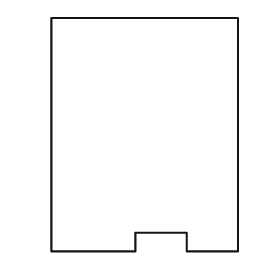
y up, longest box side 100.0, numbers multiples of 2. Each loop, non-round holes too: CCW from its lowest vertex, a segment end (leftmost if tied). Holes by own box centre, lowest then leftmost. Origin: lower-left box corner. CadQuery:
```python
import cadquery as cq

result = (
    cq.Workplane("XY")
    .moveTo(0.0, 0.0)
    .lineTo(36.0, 0.0)
    .lineTo(36.0, 8.0)
    .lineTo(58.0, 8.0)
    .lineTo(58.0, 0.0)
    .lineTo(80.0, 0.0)
    .lineTo(80.0, 100.0)
    .lineTo(0.0, 100.0)
    .close()
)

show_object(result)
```